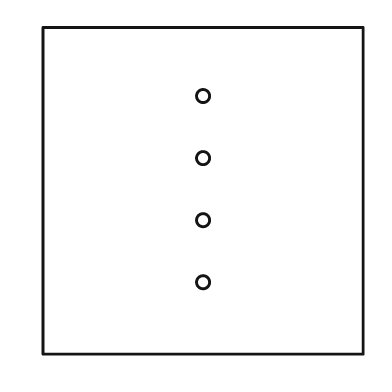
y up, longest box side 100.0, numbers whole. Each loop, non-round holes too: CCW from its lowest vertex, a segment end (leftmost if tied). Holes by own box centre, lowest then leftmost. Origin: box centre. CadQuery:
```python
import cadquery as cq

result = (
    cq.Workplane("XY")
    .moveTo(-49.0, -50.0)
    .lineTo(49.0, -50.0)
    .lineTo(49.0, 50.0)
    .lineTo(-49.0, 50.0)
    .close()
    .moveTo(0.0, -28.0)
    .circle(2.0)
    .moveTo(0.0, -9.0)
    .circle(2.0)
    .moveTo(0.0, 10.0)
    .circle(2.0)
    .moveTo(0.0, 29.0)
    .circle(2.0)
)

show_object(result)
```